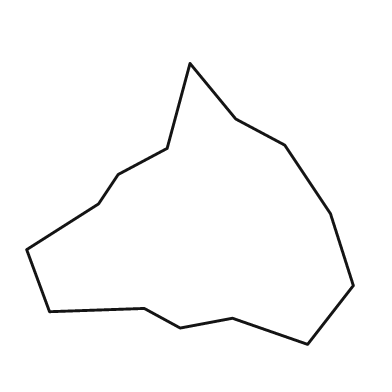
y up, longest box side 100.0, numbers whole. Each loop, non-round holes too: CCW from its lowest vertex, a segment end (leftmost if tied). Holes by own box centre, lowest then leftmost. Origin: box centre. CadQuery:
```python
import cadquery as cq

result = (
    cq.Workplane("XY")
    .moveTo(36.0, -43.0)
    .lineTo(50.0, -25.0)
    .lineTo(43.0, -3.0)
    .lineTo(29.0, 18.0)
    .lineTo(14.0, 26.0)
    .lineTo(0.0, 43.0)
    .lineTo(-7.0, 17.0)
    .lineTo(-22.0, 9.0)
    .lineTo(-28.0, 0.0)
    .lineTo(-50.0, -14.0)
    .lineTo(-43.0, -33.0)
    .lineTo(-14.0, -32.0)
    .lineTo(-3.0, -38.0)
    .lineTo(13.0, -35.0)
    .close()
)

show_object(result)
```